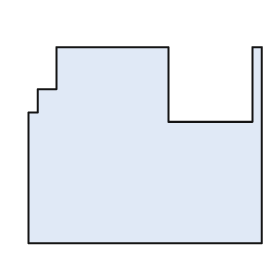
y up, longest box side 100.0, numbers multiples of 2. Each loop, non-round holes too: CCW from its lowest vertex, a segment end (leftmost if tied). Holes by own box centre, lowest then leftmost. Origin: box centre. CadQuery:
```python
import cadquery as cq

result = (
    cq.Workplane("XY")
    .moveTo(-50.0, -42.0)
    .lineTo(50.0, -42.0)
    .lineTo(50.0, 42.0)
    .lineTo(46.0, 42.0)
    .lineTo(46.0, 10.0)
    .lineTo(10.0, 10.0)
    .lineTo(10.0, 42.0)
    .lineTo(-38.0, 42.0)
    .lineTo(-38.0, 24.0)
    .lineTo(-46.0, 24.0)
    .lineTo(-46.0, 14.0)
    .lineTo(-50.0, 14.0)
    .close()
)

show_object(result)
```